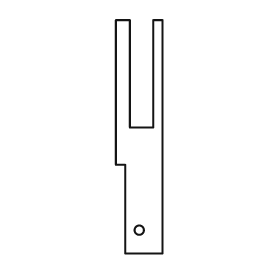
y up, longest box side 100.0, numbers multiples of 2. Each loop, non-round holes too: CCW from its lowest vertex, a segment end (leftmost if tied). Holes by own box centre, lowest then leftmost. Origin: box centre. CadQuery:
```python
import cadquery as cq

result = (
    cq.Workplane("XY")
    .moveTo(-6.0, -50.0)
    .lineTo(10.0, -50.0)
    .lineTo(10.0, 50.0)
    .lineTo(6.0, 50.0)
    .lineTo(6.0, 4.0)
    .lineTo(-4.0, 4.0)
    .lineTo(-4.0, 50.0)
    .lineTo(-10.0, 50.0)
    .lineTo(-10.0, -12.0)
    .lineTo(-6.0, -12.0)
    .close()
    .moveTo(0.0, -40.0)
    .circle(2.0)
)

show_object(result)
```